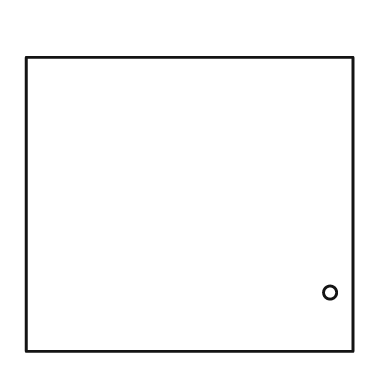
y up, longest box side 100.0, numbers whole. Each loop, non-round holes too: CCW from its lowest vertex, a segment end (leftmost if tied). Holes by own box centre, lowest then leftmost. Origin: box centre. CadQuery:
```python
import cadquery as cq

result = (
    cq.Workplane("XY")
    .moveTo(-50.0, -45.0)
    .lineTo(50.0, -45.0)
    .lineTo(50.0, 45.0)
    .lineTo(-50.0, 45.0)
    .close()
    .moveTo(43.0, -27.0)
    .circle(2.0)
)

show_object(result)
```